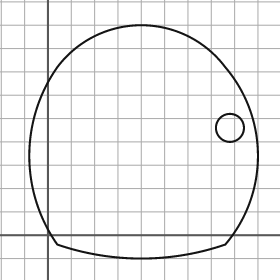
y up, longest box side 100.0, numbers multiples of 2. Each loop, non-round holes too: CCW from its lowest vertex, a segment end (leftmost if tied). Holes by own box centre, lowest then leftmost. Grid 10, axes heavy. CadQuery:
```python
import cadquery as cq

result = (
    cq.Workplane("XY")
    .moveTo(4.0, -4.0)
    .threePointArc((40.0, -10.0), (76.0, -4.0))
    .threePointArc((90.0, 34.0), (76.0, 72.0))
    .threePointArc((40.0, 90.0), (4.0, 72.0))
    .threePointArc((-8.0, 34.0), (4.0, -4.0))
    .close()
    .moveTo(78.0, 46.0)
    .circle(6.0)
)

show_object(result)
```